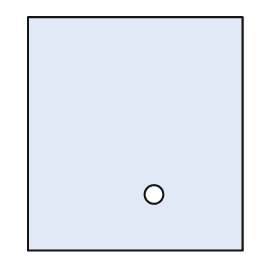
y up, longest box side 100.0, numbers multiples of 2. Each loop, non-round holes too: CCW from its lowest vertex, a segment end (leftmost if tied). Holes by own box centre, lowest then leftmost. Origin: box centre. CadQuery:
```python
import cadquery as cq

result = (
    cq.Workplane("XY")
    .moveTo(-46.0, -50.0)
    .lineTo(46.0, -50.0)
    .lineTo(46.0, 50.0)
    .lineTo(-46.0, 50.0)
    .close()
    .moveTo(8.0, -26.0)
    .circle(4.0)
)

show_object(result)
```